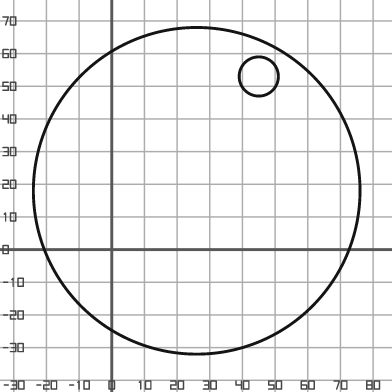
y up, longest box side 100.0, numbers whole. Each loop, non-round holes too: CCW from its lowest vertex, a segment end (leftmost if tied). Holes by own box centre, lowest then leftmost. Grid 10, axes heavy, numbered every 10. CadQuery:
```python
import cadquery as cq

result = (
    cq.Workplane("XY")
    .moveTo(26.0, 18.0)
    .circle(50.0)
    .moveTo(45.0, 53.0)
    .circle(6.0)
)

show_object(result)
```